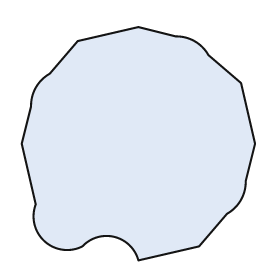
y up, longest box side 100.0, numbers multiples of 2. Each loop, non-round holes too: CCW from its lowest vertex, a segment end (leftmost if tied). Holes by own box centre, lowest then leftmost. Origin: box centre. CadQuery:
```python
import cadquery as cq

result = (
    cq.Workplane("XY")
    .moveTo(0.0, -50.0)
    .lineTo(26.0, -44.0)
    .lineTo(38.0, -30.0)
    .threePointArc((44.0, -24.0), (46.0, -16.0))
    .lineTo(50.0, 0.0)
    .lineTo(44.0, 26.0)
    .lineTo(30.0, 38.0)
    .threePointArc((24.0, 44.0), (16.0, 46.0))
    .lineTo(0.0, 50.0)
    .lineTo(-26.0, 44.0)
    .lineTo(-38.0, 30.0)
    .threePointArc((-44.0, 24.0), (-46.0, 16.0))
    .lineTo(-50.0, 0.0)
    .lineTo(-44.0, -26.0)
    .threePointArc((-40.0, -42.0), (-24.0, -44.0))
    .threePointArc((-10.0, -40.0), (0.0, -50.0))
    .close()
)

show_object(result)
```